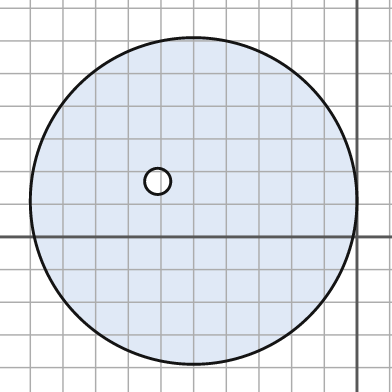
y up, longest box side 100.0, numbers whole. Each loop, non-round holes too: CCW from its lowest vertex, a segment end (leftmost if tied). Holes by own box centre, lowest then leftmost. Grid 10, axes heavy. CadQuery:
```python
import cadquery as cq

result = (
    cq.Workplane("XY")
    .moveTo(-50.0, 11.0)
    .circle(50.0)
    .moveTo(-61.0, 17.0)
    .circle(4.0)
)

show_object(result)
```